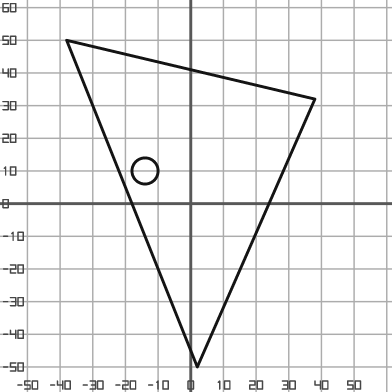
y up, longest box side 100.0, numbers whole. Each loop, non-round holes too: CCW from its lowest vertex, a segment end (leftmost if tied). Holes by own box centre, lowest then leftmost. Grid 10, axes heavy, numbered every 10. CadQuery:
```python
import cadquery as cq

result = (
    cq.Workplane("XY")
    .moveTo(2.0, -50.0)
    .lineTo(38.0, 32.0)
    .lineTo(-38.0, 50.0)
    .close()
    .moveTo(-14.0, 10.0)
    .circle(4.0)
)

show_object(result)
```